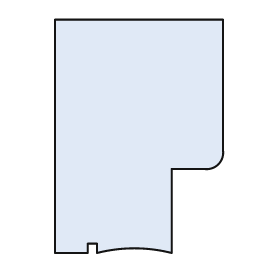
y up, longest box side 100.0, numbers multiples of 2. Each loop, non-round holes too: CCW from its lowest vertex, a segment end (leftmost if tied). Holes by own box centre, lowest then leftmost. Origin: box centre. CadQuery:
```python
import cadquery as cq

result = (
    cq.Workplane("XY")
    .moveTo(-36.0, -50.0)
    .lineTo(-22.0, -50.0)
    .lineTo(-22.0, -46.0)
    .lineTo(-18.0, -46.0)
    .lineTo(-18.0, -50.0)
    .threePointArc((-2.0, -48.0), (14.0, -50.0))
    .lineTo(14.0, -14.0)
    .lineTo(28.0, -14.0)
    .threePointArc((34.0, -12.0), (36.0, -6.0))
    .lineTo(36.0, 50.0)
    .lineTo(-36.0, 50.0)
    .close()
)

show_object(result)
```